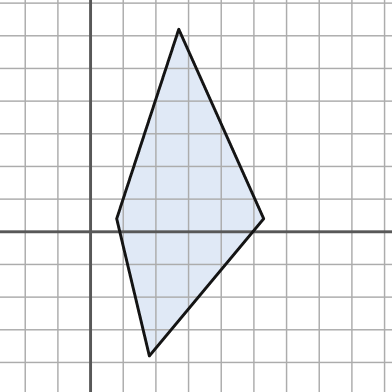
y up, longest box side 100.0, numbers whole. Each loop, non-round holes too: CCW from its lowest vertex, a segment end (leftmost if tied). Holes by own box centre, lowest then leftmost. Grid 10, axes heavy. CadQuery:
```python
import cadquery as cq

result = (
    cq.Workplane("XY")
    .moveTo(18.0, -38.0)
    .lineTo(53.0, 4.0)
    .lineTo(27.0, 62.0)
    .lineTo(8.0, 4.0)
    .close()
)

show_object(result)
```